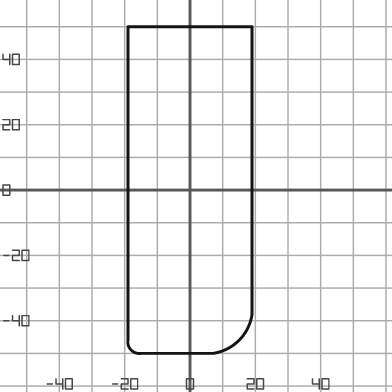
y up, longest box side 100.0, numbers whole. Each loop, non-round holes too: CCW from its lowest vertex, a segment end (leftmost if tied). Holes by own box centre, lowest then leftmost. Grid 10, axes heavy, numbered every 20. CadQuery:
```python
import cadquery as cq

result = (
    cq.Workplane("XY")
    .moveTo(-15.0, -50.0)
    .lineTo(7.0, -50.0)
    .threePointArc((15.0, -46.0), (19.0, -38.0))
    .lineTo(19.0, 50.0)
    .lineTo(-19.0, 50.0)
    .lineTo(-19.0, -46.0)
    .threePointArc((-18.0, -49.0), (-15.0, -50.0))
    .close()
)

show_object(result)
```